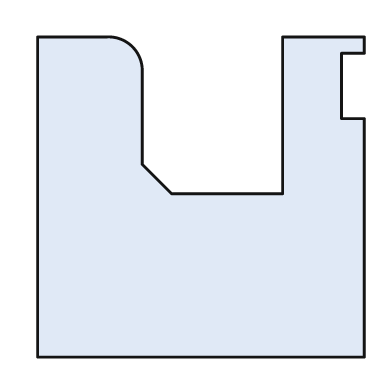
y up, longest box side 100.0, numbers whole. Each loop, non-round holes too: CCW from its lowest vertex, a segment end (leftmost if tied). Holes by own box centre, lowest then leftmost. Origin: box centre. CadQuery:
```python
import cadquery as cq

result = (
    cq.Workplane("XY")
    .moveTo(-50.0, -49.0)
    .lineTo(50.0, -49.0)
    .lineTo(50.0, 24.0)
    .lineTo(43.0, 24.0)
    .lineTo(43.0, 44.0)
    .lineTo(50.0, 44.0)
    .lineTo(50.0, 49.0)
    .lineTo(25.0, 49.0)
    .lineTo(25.0, 1.0)
    .lineTo(-9.0, 1.0)
    .lineTo(-18.0, 10.0)
    .lineTo(-18.0, 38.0)
    .threePointArc((-21.0, 46.0), (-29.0, 49.0))
    .lineTo(-50.0, 49.0)
    .close()
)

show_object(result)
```